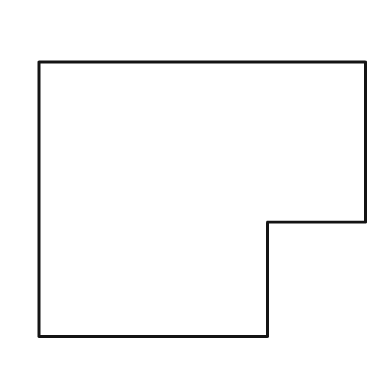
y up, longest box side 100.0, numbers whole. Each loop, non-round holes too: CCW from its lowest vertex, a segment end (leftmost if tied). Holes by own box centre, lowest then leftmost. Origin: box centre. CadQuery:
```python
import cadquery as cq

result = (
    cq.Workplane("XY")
    .moveTo(-50.0, -42.0)
    .lineTo(20.0, -42.0)
    .lineTo(20.0, -7.0)
    .lineTo(50.0, -7.0)
    .lineTo(50.0, 42.0)
    .lineTo(-50.0, 42.0)
    .close()
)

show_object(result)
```